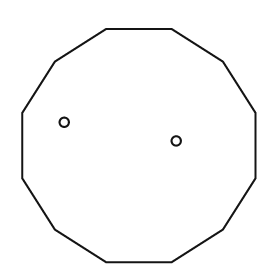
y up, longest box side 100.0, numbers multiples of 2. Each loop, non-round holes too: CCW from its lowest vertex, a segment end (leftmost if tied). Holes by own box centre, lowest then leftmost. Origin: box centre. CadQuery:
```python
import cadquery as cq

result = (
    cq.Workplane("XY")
    .moveTo(-14.0, -50.0)
    .lineTo(14.0, -50.0)
    .lineTo(36.0, -36.0)
    .lineTo(50.0, -14.0)
    .lineTo(50.0, 14.0)
    .lineTo(36.0, 36.0)
    .lineTo(14.0, 50.0)
    .lineTo(-14.0, 50.0)
    .lineTo(-36.0, 36.0)
    .lineTo(-50.0, 14.0)
    .lineTo(-50.0, -14.0)
    .lineTo(-36.0, -36.0)
    .close()
    .moveTo(16.0, 2.0)
    .circle(2.0)
    .moveTo(-32.0, 10.0)
    .circle(2.0)
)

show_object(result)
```